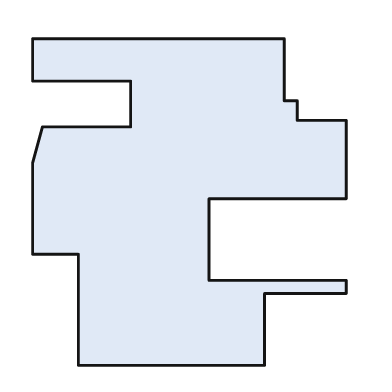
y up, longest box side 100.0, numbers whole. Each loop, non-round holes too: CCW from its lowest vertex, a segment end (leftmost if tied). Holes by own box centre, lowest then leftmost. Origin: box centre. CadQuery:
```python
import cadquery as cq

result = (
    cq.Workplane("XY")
    .moveTo(-34.0, -50.0)
    .lineTo(23.0, -50.0)
    .lineTo(23.0, -28.0)
    .lineTo(48.0, -28.0)
    .lineTo(48.0, -24.0)
    .lineTo(6.0, -24.0)
    .lineTo(6.0, 1.0)
    .lineTo(48.0, 1.0)
    .lineTo(48.0, 25.0)
    .lineTo(33.0, 25.0)
    .lineTo(33.0, 31.0)
    .lineTo(29.0, 31.0)
    .lineTo(29.0, 50.0)
    .lineTo(-48.0, 50.0)
    .lineTo(-48.0, 37.0)
    .lineTo(-18.0, 37.0)
    .lineTo(-18.0, 23.0)
    .lineTo(-45.0, 23.0)
    .lineTo(-48.0, 12.0)
    .lineTo(-48.0, -16.0)
    .lineTo(-34.0, -16.0)
    .close()
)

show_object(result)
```